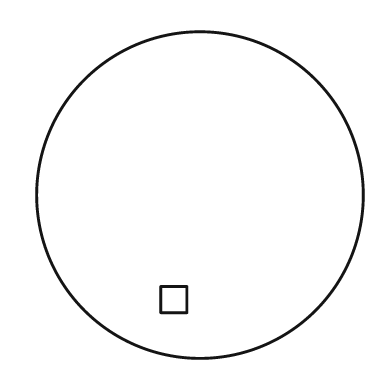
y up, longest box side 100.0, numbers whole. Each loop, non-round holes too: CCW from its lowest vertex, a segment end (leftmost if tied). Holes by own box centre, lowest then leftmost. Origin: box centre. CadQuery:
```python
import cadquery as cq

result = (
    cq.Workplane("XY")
    .moveTo(0.0, 0.0)
    .circle(50.0)
    .moveTo(-12.0, -36.0)
    .lineTo(-4.0, -36.0)
    .lineTo(-4.0, -28.0)
    .lineTo(-12.0, -28.0)
    .close()
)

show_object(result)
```